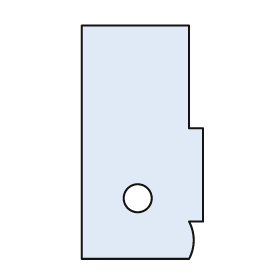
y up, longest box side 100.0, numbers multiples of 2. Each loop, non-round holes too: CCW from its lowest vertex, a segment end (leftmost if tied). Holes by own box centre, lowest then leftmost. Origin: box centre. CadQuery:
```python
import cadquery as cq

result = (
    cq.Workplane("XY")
    .moveTo(-26.0, -50.0)
    .lineTo(20.0, -50.0)
    .threePointArc((22.0, -42.0), (20.0, -34.0))
    .lineTo(26.0, -34.0)
    .lineTo(26.0, 6.0)
    .lineTo(20.0, 6.0)
    .lineTo(20.0, 50.0)
    .lineTo(-26.0, 50.0)
    .close()
    .moveTo(-2.0, -24.0)
    .circle(6.0)
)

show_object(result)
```